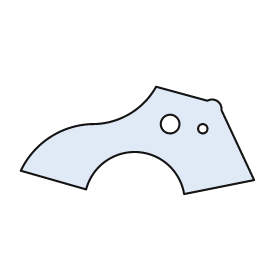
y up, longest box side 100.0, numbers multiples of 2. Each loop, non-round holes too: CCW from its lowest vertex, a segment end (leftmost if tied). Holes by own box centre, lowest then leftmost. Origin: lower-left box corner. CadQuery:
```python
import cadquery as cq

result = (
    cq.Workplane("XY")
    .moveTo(70.0, 0.0)
    .lineTo(100.0, 6.0)
    .lineTo(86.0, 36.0)
    .threePointArc((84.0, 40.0), (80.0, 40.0))
    .lineTo(58.0, 46.0)
    .threePointArc((46.0, 34.0), (30.0, 30.0))
    .threePointArc((12.0, 24.0), (0.0, 10.0))
    .lineTo(28.0, 2.0)
    .threePointArc((50.0, 18.0), (70.0, 0.0))
    .close()
    .moveTo(78.0, 28.0)
    .circle(2.0)
    .moveTo(64.0, 30.0)
    .circle(4.0)
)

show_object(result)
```